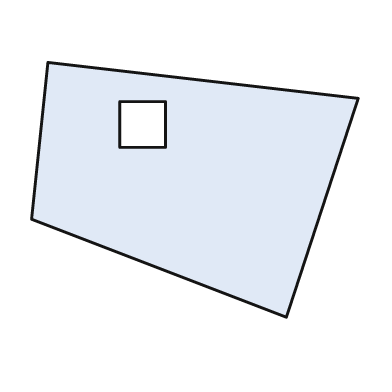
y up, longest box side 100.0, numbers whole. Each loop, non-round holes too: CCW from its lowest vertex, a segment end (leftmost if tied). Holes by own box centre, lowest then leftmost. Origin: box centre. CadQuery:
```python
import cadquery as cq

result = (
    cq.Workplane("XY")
    .moveTo(28.0, -39.0)
    .lineTo(50.0, 28.0)
    .lineTo(-45.0, 39.0)
    .lineTo(-50.0, -9.0)
    .close()
    .moveTo(-23.0, 13.0)
    .lineTo(-9.0, 13.0)
    .lineTo(-9.0, 27.0)
    .lineTo(-23.0, 27.0)
    .close()
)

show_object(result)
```